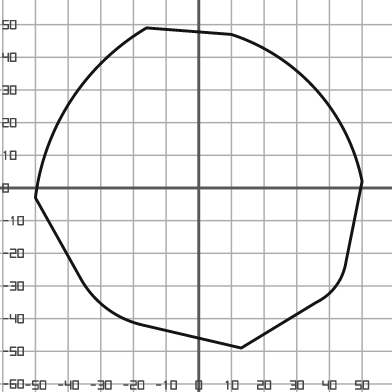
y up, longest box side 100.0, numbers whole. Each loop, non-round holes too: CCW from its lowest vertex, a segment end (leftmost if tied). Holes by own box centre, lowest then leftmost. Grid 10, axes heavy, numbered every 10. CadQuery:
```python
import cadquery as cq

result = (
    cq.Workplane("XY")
    .moveTo(13.0, -49.0)
    .lineTo(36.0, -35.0)
    .threePointArc((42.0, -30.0), (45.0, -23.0))
    .lineTo(50.0, 2.0)
    .threePointArc((36.0, 30.0), (10.0, 47.0))
    .lineTo(-16.0, 49.0)
    .threePointArc((-39.0, 27.0), (-50.0, -3.0))
    .lineTo(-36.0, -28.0)
    .threePointArc((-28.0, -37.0), (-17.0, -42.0))
    .close()
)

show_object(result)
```